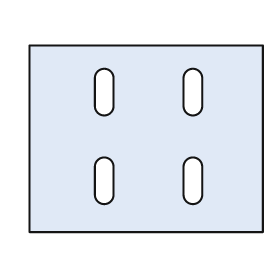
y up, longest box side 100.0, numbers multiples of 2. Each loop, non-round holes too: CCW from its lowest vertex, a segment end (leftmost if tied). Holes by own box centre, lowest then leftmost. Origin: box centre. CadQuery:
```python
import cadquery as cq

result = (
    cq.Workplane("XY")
    .moveTo(-50.0, -40.0)
    .lineTo(50.0, -40.0)
    .lineTo(50.0, 40.0)
    .lineTo(-50.0, 40.0)
    .close()
    .moveTo(-22.0, -24.0)
    .threePointArc((-18.0, -28.0), (-14.0, -24.0))
    .lineTo(-14.0, -12.0)
    .threePointArc((-18.0, -8.0), (-22.0, -12.0))
    .close()
    .moveTo(16.0, -24.0)
    .threePointArc((20.0, -28.0), (24.0, -24.0))
    .lineTo(24.0, -12.0)
    .threePointArc((20.0, -8.0), (16.0, -12.0))
    .close()
    .moveTo(-22.0, 14.0)
    .threePointArc((-18.0, 10.0), (-14.0, 14.0))
    .lineTo(-14.0, 26.0)
    .threePointArc((-18.0, 30.0), (-22.0, 26.0))
    .close()
    .moveTo(16.0, 14.0)
    .threePointArc((20.0, 10.0), (24.0, 14.0))
    .lineTo(24.0, 26.0)
    .threePointArc((20.0, 30.0), (16.0, 26.0))
    .close()
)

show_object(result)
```